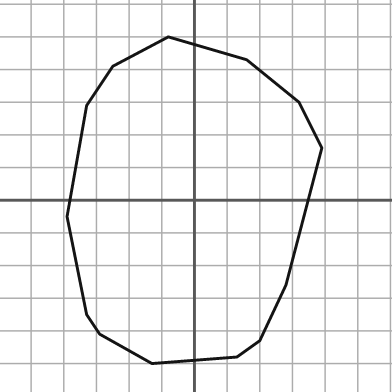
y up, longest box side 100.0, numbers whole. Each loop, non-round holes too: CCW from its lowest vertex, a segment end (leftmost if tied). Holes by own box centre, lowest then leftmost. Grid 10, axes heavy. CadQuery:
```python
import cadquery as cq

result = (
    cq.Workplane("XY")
    .moveTo(-13.0, -50.0)
    .lineTo(13.0, -48.0)
    .lineTo(20.0, -43.0)
    .lineTo(28.0, -26.0)
    .lineTo(39.0, 16.0)
    .lineTo(32.0, 30.0)
    .lineTo(16.0, 43.0)
    .lineTo(-8.0, 50.0)
    .lineTo(-25.0, 41.0)
    .lineTo(-33.0, 29.0)
    .lineTo(-39.0, -5.0)
    .lineTo(-33.0, -35.0)
    .lineTo(-29.0, -41.0)
    .close()
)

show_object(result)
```